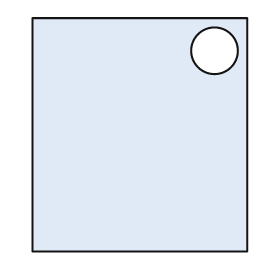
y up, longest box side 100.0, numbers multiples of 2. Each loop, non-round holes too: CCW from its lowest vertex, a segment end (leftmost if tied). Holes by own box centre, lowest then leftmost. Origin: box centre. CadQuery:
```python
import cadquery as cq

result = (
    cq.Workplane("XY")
    .moveTo(-46.0, -50.0)
    .lineTo(46.0, -50.0)
    .lineTo(46.0, 50.0)
    .lineTo(-46.0, 50.0)
    .close()
    .moveTo(32.0, 36.0)
    .circle(10.0)
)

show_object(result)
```